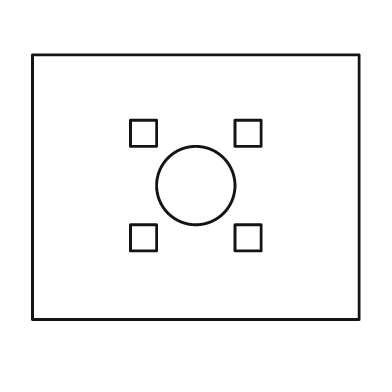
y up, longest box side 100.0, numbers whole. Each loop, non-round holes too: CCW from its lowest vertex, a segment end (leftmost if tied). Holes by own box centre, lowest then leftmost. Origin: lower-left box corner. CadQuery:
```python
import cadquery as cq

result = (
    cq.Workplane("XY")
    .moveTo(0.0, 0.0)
    .lineTo(100.0, 0.0)
    .lineTo(100.0, 81.0)
    .lineTo(0.0, 81.0)
    .close()
    .moveTo(30.0, 21.0)
    .lineTo(38.0, 21.0)
    .lineTo(38.0, 29.0)
    .lineTo(30.0, 29.0)
    .close()
    .moveTo(62.0, 21.0)
    .lineTo(70.0, 21.0)
    .lineTo(70.0, 29.0)
    .lineTo(62.0, 29.0)
    .close()
    .moveTo(50.0, 41.0)
    .circle(12.0)
    .moveTo(30.0, 53.0)
    .lineTo(38.0, 53.0)
    .lineTo(38.0, 61.0)
    .lineTo(30.0, 61.0)
    .close()
    .moveTo(62.0, 53.0)
    .lineTo(70.0, 53.0)
    .lineTo(70.0, 61.0)
    .lineTo(62.0, 61.0)
    .close()
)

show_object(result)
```